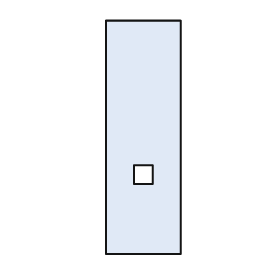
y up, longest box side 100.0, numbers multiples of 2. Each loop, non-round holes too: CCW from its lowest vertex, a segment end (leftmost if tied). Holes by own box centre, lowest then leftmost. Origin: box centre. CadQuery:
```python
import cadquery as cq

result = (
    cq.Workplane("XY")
    .moveTo(-16.0, -50.0)
    .lineTo(16.0, -50.0)
    .lineTo(16.0, 50.0)
    .lineTo(-16.0, 50.0)
    .close()
    .moveTo(-4.0, -20.0)
    .lineTo(4.0, -20.0)
    .lineTo(4.0, -12.0)
    .lineTo(-4.0, -12.0)
    .close()
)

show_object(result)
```